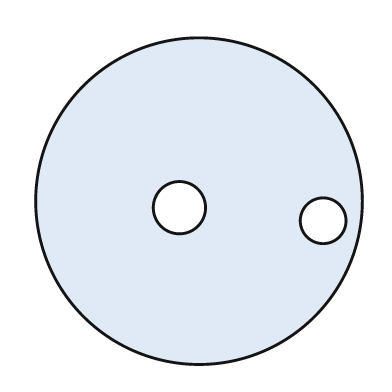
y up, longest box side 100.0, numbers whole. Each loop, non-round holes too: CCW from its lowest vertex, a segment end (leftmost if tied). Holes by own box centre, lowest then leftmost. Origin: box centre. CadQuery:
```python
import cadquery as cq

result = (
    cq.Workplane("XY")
    .moveTo(0.0, 0.0)
    .circle(50.0)
    .moveTo(38.0, -6.0)
    .circle(7.0)
    .moveTo(-6.0, -2.0)
    .circle(8.0)
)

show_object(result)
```